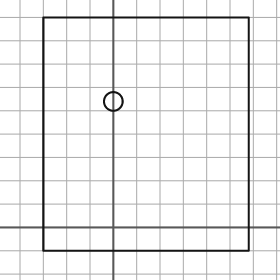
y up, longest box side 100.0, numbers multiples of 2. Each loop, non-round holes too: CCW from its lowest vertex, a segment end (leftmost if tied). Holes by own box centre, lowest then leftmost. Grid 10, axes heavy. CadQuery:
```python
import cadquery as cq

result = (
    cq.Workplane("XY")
    .moveTo(-30.0, -10.0)
    .lineTo(58.0, -10.0)
    .lineTo(58.0, 90.0)
    .lineTo(-30.0, 90.0)
    .close()
    .moveTo(0.0, 54.0)
    .circle(4.0)
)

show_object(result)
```